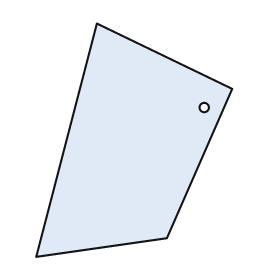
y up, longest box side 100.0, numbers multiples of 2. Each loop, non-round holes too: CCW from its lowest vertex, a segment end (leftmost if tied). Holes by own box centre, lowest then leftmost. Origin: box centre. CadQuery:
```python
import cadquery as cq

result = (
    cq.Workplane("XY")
    .moveTo(-42.0, -50.0)
    .lineTo(14.0, -42.0)
    .lineTo(42.0, 22.0)
    .lineTo(-16.0, 50.0)
    .close()
    .moveTo(30.0, 14.0)
    .circle(2.0)
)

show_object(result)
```